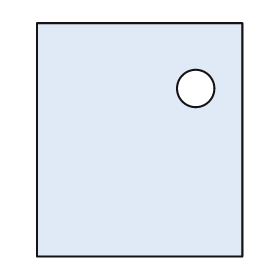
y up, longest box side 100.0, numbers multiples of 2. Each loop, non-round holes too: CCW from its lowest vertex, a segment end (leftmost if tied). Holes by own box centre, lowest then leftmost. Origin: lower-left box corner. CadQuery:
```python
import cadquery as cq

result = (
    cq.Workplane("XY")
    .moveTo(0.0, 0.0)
    .lineTo(88.0, 0.0)
    .lineTo(88.0, 100.0)
    .lineTo(0.0, 100.0)
    .close()
    .moveTo(68.0, 72.0)
    .circle(8.0)
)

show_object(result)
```